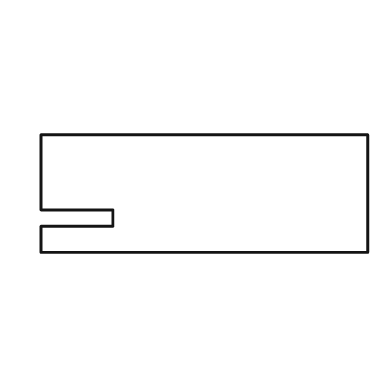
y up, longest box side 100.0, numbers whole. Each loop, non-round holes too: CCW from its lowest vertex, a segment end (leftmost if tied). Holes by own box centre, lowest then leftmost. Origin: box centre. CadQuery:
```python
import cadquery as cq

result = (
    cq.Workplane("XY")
    .moveTo(-50.0, -18.0)
    .lineTo(50.0, -18.0)
    .lineTo(50.0, 18.0)
    .lineTo(-50.0, 18.0)
    .lineTo(-50.0, -5.0)
    .lineTo(-28.0, -5.0)
    .lineTo(-28.0, -10.0)
    .lineTo(-50.0, -10.0)
    .close()
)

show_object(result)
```